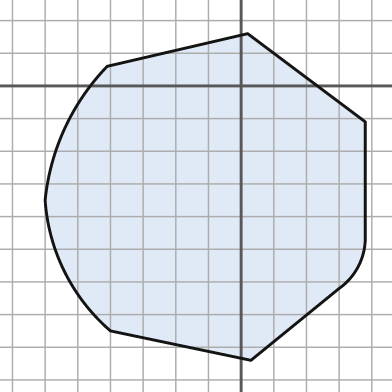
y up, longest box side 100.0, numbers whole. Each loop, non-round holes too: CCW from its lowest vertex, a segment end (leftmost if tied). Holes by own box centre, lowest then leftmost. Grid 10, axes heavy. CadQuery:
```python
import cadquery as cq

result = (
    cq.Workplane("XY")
    .moveTo(3.0, -84.0)
    .lineTo(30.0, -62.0)
    .threePointArc((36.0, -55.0), (38.0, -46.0))
    .lineTo(38.0, -11.0)
    .lineTo(2.0, 16.0)
    .lineTo(-41.0, 6.0)
    .threePointArc((-54.0, -13.0), (-60.0, -35.0))
    .threePointArc((-54.0, -57.0), (-40.0, -75.0))
    .close()
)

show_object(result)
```